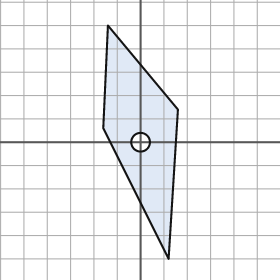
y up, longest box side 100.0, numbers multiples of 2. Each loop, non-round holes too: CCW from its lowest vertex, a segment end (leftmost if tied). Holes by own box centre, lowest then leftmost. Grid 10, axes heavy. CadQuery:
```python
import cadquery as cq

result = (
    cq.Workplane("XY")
    .moveTo(12.0, -50.0)
    .lineTo(16.0, 14.0)
    .lineTo(-14.0, 50.0)
    .lineTo(-16.0, 6.0)
    .close()
    .moveTo(0.0, 0.0)
    .circle(4.0)
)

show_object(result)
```